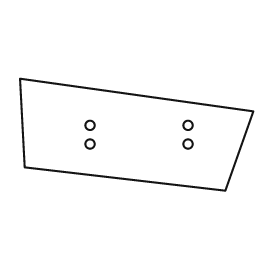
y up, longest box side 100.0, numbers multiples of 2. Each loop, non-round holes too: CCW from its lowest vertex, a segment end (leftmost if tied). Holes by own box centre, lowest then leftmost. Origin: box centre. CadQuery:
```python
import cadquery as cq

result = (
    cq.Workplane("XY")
    .moveTo(38.0, -24.0)
    .lineTo(50.0, 10.0)
    .lineTo(-50.0, 24.0)
    .lineTo(-48.0, -14.0)
    .close()
    .moveTo(-20.0, -4.0)
    .circle(2.0)
    .moveTo(22.0, -4.0)
    .circle(2.0)
    .moveTo(-20.0, 4.0)
    .circle(2.0)
    .moveTo(22.0, 4.0)
    .circle(2.0)
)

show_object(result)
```